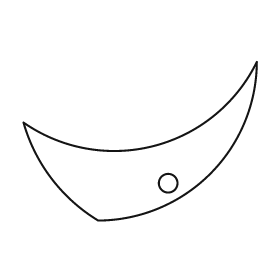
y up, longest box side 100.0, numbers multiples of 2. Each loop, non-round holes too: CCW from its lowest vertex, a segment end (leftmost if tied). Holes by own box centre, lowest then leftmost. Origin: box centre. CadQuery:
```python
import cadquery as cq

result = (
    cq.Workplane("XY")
    .moveTo(-18.0, -34.0)
    .threePointArc((30.0, -14.0), (50.0, 34.0))
    .threePointArc((6.0, -2.0), (-50.0, 8.0))
    .threePointArc((-38.0, -16.0), (-18.0, -34.0))
    .close()
    .moveTo(12.0, -18.0)
    .circle(4.0)
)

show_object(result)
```